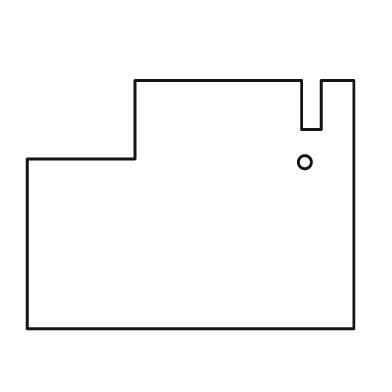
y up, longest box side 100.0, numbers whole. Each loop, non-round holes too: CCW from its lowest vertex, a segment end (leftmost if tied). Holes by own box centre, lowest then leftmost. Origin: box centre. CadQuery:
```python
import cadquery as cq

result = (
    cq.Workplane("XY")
    .moveTo(-50.0, -38.0)
    .lineTo(50.0, -38.0)
    .lineTo(50.0, 38.0)
    .lineTo(40.0, 38.0)
    .lineTo(40.0, 23.0)
    .lineTo(34.0, 23.0)
    .lineTo(34.0, 38.0)
    .lineTo(-17.0, 38.0)
    .lineTo(-17.0, 14.0)
    .lineTo(-50.0, 14.0)
    .close()
    .moveTo(35.0, 13.0)
    .circle(2.0)
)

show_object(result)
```